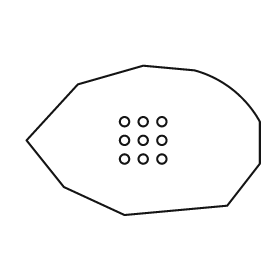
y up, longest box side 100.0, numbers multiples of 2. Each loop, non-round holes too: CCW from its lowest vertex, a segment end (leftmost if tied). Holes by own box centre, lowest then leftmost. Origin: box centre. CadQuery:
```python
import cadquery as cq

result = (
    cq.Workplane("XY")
    .moveTo(-8.0, -32.0)
    .lineTo(36.0, -28.0)
    .lineTo(50.0, -10.0)
    .lineTo(50.0, 8.0)
    .threePointArc((38.0, 22.0), (22.0, 30.0))
    .lineTo(0.0, 32.0)
    .lineTo(-28.0, 24.0)
    .lineTo(-50.0, 0.0)
    .lineTo(-34.0, -20.0)
    .close()
    .moveTo(-8.0, -8.0)
    .circle(2.0)
    .moveTo(0.0, -8.0)
    .circle(2.0)
    .moveTo(8.0, -8.0)
    .circle(2.0)
    .moveTo(-8.0, 0.0)
    .circle(2.0)
    .moveTo(0.0, 0.0)
    .circle(2.0)
    .moveTo(8.0, 0.0)
    .circle(2.0)
    .moveTo(-8.0, 8.0)
    .circle(2.0)
    .moveTo(0.0, 8.0)
    .circle(2.0)
    .moveTo(8.0, 8.0)
    .circle(2.0)
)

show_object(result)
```